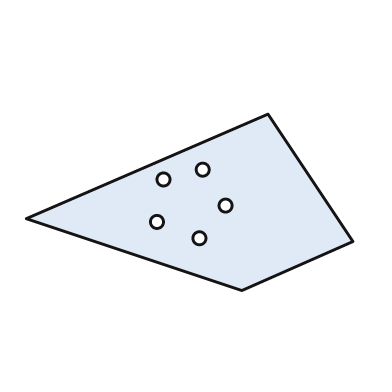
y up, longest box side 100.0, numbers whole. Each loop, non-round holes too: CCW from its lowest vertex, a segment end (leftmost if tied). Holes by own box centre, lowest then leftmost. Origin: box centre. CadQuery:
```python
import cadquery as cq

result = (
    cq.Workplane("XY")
    .moveTo(16.0, -27.0)
    .lineTo(50.0, -12.0)
    .lineTo(24.0, 27.0)
    .lineTo(-50.0, -5.0)
    .close()
    .moveTo(3.0, -11.0)
    .circle(2.0)
    .moveTo(-10.0, -6.0)
    .circle(2.0)
    .moveTo(11.0, -1.0)
    .circle(2.0)
    .moveTo(-8.0, 7.0)
    .circle(2.0)
    .moveTo(4.0, 10.0)
    .circle(2.0)
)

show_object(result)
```